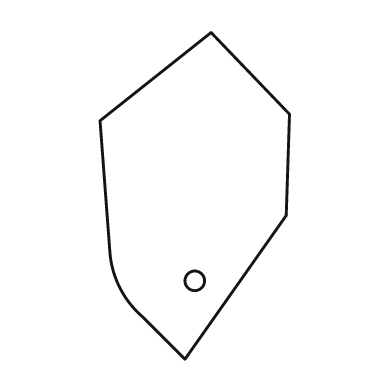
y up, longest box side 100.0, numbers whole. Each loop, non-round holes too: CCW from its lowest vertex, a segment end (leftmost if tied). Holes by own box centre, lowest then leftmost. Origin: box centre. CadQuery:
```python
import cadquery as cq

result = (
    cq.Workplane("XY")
    .moveTo(-3.0, -50.0)
    .lineTo(28.0, -6.0)
    .lineTo(29.0, 25.0)
    .lineTo(5.0, 50.0)
    .lineTo(-29.0, 23.0)
    .lineTo(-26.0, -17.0)
    .threePointArc((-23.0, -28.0), (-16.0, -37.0))
    .close()
    .moveTo(0.0, -26.0)
    .circle(3.0)
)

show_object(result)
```